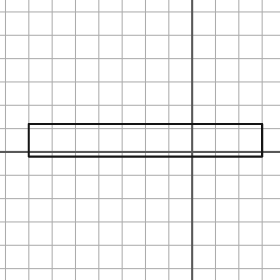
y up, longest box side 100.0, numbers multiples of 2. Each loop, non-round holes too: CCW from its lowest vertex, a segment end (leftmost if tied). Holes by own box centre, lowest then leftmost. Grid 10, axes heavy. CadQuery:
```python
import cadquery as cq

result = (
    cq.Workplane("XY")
    .moveTo(-70.0, -2.0)
    .lineTo(30.0, -2.0)
    .lineTo(30.0, 12.0)
    .lineTo(-70.0, 12.0)
    .close()
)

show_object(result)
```